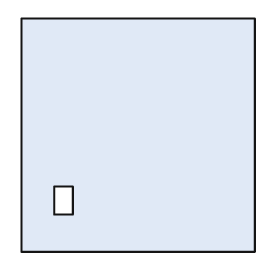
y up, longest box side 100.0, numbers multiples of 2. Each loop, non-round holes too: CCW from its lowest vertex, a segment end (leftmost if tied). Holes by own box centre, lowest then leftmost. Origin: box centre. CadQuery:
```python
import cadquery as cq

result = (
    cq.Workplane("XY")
    .moveTo(-50.0, -50.0)
    .lineTo(50.0, -50.0)
    .lineTo(50.0, 50.0)
    .lineTo(-50.0, 50.0)
    .close()
    .moveTo(-36.0, -34.0)
    .lineTo(-28.0, -34.0)
    .lineTo(-28.0, -22.0)
    .lineTo(-36.0, -22.0)
    .close()
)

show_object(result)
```